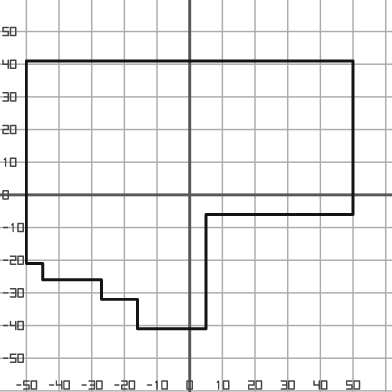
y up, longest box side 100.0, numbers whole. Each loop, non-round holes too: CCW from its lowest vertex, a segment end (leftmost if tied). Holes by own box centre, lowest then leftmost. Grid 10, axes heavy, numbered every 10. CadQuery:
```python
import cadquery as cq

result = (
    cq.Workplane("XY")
    .moveTo(-16.0, -41.0)
    .lineTo(5.0, -41.0)
    .lineTo(5.0, -6.0)
    .lineTo(50.0, -6.0)
    .lineTo(50.0, 41.0)
    .lineTo(-50.0, 41.0)
    .lineTo(-50.0, -21.0)
    .lineTo(-45.0, -21.0)
    .lineTo(-45.0, -26.0)
    .lineTo(-27.0, -26.0)
    .lineTo(-27.0, -32.0)
    .lineTo(-16.0, -32.0)
    .close()
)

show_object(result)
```